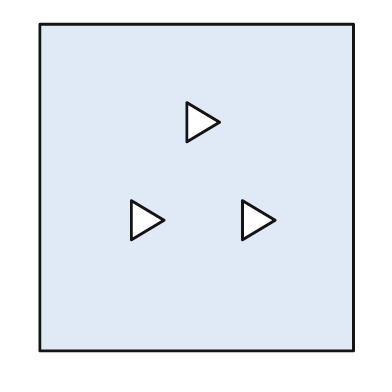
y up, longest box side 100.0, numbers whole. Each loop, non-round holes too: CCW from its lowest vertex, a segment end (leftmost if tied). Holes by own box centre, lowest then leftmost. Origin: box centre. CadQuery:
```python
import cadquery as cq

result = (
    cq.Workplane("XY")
    .moveTo(-48.0, -50.0)
    .lineTo(48.0, -50.0)
    .lineTo(48.0, 50.0)
    .lineTo(-48.0, 50.0)
    .close()
    .moveTo(-20.0, -16.0)
    .lineTo(-10.0, -10.0)
    .lineTo(-20.0, -4.0)
    .close()
    .moveTo(14.0, -16.0)
    .lineTo(24.0, -10.0)
    .lineTo(14.0, -4.0)
    .close()
    .moveTo(-3.0, 14.0)
    .lineTo(7.0, 20.0)
    .lineTo(-3.0, 26.0)
    .close()
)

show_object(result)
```